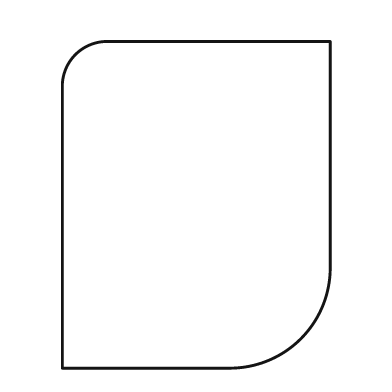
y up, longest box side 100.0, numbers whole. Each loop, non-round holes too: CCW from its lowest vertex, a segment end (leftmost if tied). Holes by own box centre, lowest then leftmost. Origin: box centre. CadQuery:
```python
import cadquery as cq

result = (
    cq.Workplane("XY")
    .moveTo(-41.0, -50.0)
    .lineTo(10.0, -50.0)
    .threePointArc((32.0, -41.0), (41.0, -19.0))
    .lineTo(41.0, 50.0)
    .lineTo(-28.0, 50.0)
    .threePointArc((-37.0, 46.0), (-41.0, 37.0))
    .close()
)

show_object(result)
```